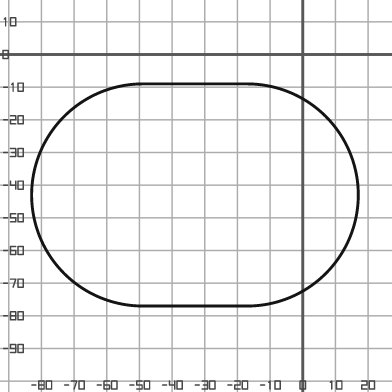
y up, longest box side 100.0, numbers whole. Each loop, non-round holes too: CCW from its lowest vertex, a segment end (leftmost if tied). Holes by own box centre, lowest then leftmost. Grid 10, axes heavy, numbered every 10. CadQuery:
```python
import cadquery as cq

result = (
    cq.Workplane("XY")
    .moveTo(-49.0, -77.0)
    .lineTo(-17.0, -77.0)
    .threePointArc((17.0, -43.0), (-17.0, -9.0))
    .lineTo(-49.0, -9.0)
    .threePointArc((-83.0, -43.0), (-49.0, -77.0))
    .close()
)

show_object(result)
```